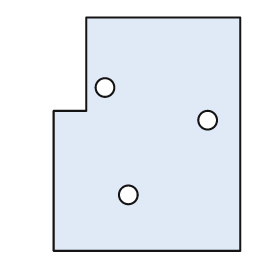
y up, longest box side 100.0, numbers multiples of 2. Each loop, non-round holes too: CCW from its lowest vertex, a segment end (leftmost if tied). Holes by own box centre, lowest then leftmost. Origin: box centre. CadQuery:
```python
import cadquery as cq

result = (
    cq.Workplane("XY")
    .moveTo(-40.0, -50.0)
    .lineTo(40.0, -50.0)
    .lineTo(40.0, 50.0)
    .lineTo(-26.0, 50.0)
    .lineTo(-26.0, 10.0)
    .lineTo(-40.0, 10.0)
    .close()
    .moveTo(-8.0, -26.0)
    .circle(4.0)
    .moveTo(26.0, 6.0)
    .circle(4.0)
    .moveTo(-18.0, 20.0)
    .circle(4.0)
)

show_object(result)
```